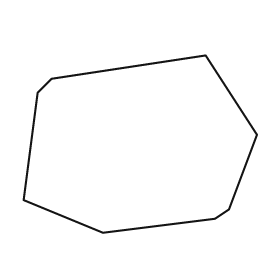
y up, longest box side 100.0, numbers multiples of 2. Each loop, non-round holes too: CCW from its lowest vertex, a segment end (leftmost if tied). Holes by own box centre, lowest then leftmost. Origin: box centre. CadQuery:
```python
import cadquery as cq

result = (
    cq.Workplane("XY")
    .moveTo(-16.0, -38.0)
    .lineTo(32.0, -32.0)
    .lineTo(38.0, -28.0)
    .lineTo(50.0, 4.0)
    .lineTo(28.0, 38.0)
    .lineTo(-38.0, 28.0)
    .lineTo(-44.0, 22.0)
    .lineTo(-50.0, -24.0)
    .close()
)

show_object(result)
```